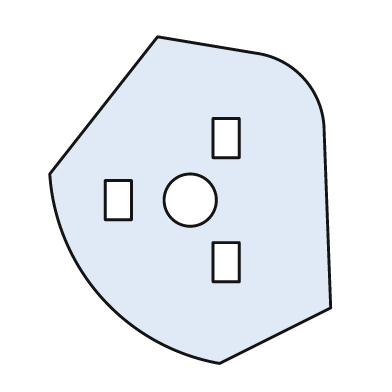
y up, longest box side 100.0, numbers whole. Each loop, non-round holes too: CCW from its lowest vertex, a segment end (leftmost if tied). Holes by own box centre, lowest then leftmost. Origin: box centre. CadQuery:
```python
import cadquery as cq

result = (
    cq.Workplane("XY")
    .moveTo(9.0, -50.0)
    .lineTo(43.0, -33.0)
    .lineTo(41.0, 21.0)
    .threePointArc((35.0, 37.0), (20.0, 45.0))
    .lineTo(-10.0, 50.0)
    .lineTo(-43.0, 8.0)
    .threePointArc((-27.0, -30.0), (9.0, -50.0))
    .close()
    .moveTo(7.0, -25.0)
    .lineTo(15.0, -25.0)
    .lineTo(15.0, -13.0)
    .lineTo(7.0, -13.0)
    .close()
    .moveTo(-26.0, -6.0)
    .lineTo(-18.0, -6.0)
    .lineTo(-18.0, 6.0)
    .lineTo(-26.0, 6.0)
    .close()
    .moveTo(0.0, 0.0)
    .circle(8.0)
    .moveTo(7.0, 13.0)
    .lineTo(15.0, 13.0)
    .lineTo(15.0, 25.0)
    .lineTo(7.0, 25.0)
    .close()
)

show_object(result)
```